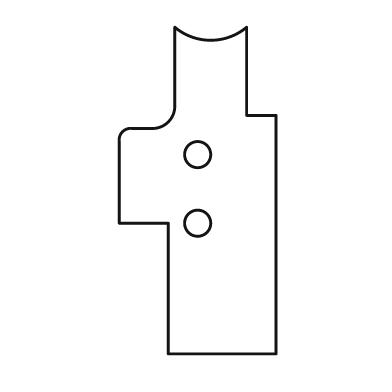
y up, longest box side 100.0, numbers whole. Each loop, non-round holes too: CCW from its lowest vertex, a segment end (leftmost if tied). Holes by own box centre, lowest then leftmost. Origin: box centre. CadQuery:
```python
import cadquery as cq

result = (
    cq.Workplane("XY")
    .moveTo(-9.0, -50.0)
    .lineTo(24.0, -50.0)
    .lineTo(24.0, 23.0)
    .lineTo(15.0, 23.0)
    .lineTo(15.0, 50.0)
    .threePointArc((4.0, 46.0), (-7.0, 50.0))
    .lineTo(-7.0, 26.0)
    .threePointArc((-9.0, 21.0), (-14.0, 19.0))
    .lineTo(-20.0, 19.0)
    .threePointArc((-23.0, 18.0), (-24.0, 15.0))
    .lineTo(-24.0, -10.0)
    .lineTo(-9.0, -10.0)
    .close()
    .moveTo(0.0, -10.0)
    .circle(4.0)
    .moveTo(0.0, 11.0)
    .circle(4.0)
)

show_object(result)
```